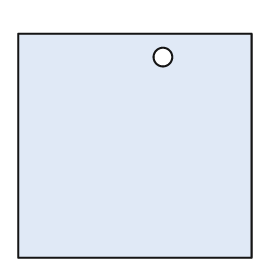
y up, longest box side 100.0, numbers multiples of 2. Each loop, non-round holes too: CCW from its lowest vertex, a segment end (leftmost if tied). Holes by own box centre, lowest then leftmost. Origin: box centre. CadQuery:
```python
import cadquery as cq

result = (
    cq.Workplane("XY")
    .moveTo(-50.0, -48.0)
    .lineTo(50.0, -48.0)
    .lineTo(50.0, 48.0)
    .lineTo(-50.0, 48.0)
    .close()
    .moveTo(12.0, 38.0)
    .circle(4.0)
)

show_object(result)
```